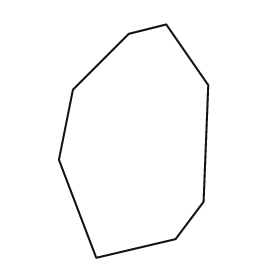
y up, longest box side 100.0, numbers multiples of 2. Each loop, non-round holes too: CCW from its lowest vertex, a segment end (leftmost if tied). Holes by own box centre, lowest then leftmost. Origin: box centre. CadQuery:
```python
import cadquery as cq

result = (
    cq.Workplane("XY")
    .moveTo(-16.0, -50.0)
    .lineTo(18.0, -42.0)
    .lineTo(30.0, -26.0)
    .lineTo(32.0, 24.0)
    .lineTo(14.0, 50.0)
    .lineTo(-2.0, 46.0)
    .lineTo(-26.0, 22.0)
    .lineTo(-32.0, -8.0)
    .close()
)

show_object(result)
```